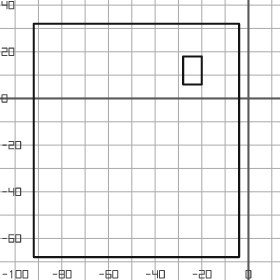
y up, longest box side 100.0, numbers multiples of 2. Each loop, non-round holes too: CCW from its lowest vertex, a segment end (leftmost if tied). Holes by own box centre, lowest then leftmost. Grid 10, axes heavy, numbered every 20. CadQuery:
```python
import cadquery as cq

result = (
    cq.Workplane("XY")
    .moveTo(-92.0, -68.0)
    .lineTo(-4.0, -68.0)
    .lineTo(-4.0, 32.0)
    .lineTo(-92.0, 32.0)
    .close()
    .moveTo(-28.0, 6.0)
    .lineTo(-20.0, 6.0)
    .lineTo(-20.0, 18.0)
    .lineTo(-28.0, 18.0)
    .close()
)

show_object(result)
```